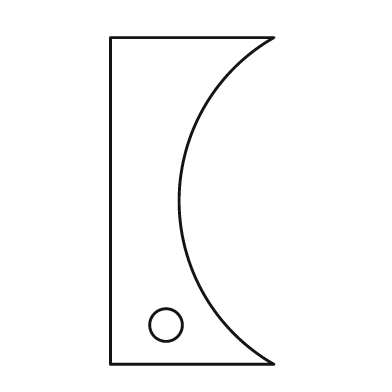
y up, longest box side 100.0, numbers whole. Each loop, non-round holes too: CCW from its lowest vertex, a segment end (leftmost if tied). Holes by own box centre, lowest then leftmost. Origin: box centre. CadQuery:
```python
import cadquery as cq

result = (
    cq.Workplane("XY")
    .moveTo(-25.0, -50.0)
    .lineTo(25.0, -50.0)
    .threePointArc((-4.0, 0.0), (25.0, 50.0))
    .lineTo(-25.0, 50.0)
    .close()
    .moveTo(-8.0, -38.0)
    .circle(5.0)
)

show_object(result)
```